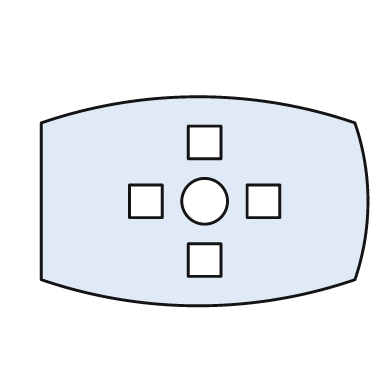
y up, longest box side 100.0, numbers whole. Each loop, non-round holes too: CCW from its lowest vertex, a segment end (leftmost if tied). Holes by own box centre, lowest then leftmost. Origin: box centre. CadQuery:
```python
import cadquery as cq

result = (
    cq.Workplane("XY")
    .moveTo(-50.0, -24.0)
    .threePointArc((-2.0, -32.0), (46.0, -24.0))
    .threePointArc((50.0, 0.0), (46.0, 24.0))
    .threePointArc((-2.0, 32.0), (-50.0, 24.0))
    .close()
    .moveTo(-5.0, -23.0)
    .lineTo(5.0, -23.0)
    .lineTo(5.0, -13.0)
    .lineTo(-5.0, -13.0)
    .close()
    .moveTo(-23.0, -5.0)
    .lineTo(-13.0, -5.0)
    .lineTo(-13.0, 5.0)
    .lineTo(-23.0, 5.0)
    .close()
    .moveTo(0.0, 0.0)
    .circle(7.0)
    .moveTo(13.0, -5.0)
    .lineTo(23.0, -5.0)
    .lineTo(23.0, 5.0)
    .lineTo(13.0, 5.0)
    .close()
    .moveTo(-5.0, 13.0)
    .lineTo(5.0, 13.0)
    .lineTo(5.0, 23.0)
    .lineTo(-5.0, 23.0)
    .close()
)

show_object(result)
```